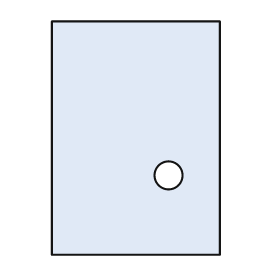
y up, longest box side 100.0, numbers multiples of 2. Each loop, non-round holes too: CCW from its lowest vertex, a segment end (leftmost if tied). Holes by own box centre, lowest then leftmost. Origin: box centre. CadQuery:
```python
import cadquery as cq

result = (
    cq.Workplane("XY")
    .moveTo(-36.0, -50.0)
    .lineTo(36.0, -50.0)
    .lineTo(36.0, 50.0)
    .lineTo(-36.0, 50.0)
    .close()
    .moveTo(14.0, -16.0)
    .circle(6.0)
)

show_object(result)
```